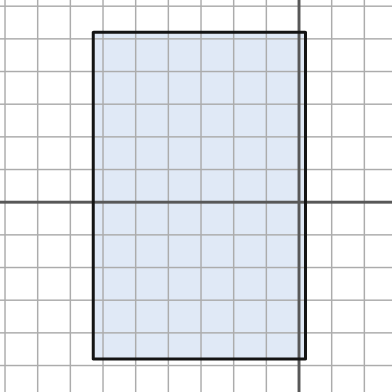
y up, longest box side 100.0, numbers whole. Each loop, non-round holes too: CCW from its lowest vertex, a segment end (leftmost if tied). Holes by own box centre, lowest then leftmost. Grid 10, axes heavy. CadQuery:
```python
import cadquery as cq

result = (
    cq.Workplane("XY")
    .moveTo(-63.0, -48.0)
    .lineTo(2.0, -48.0)
    .lineTo(2.0, 52.0)
    .lineTo(-63.0, 52.0)
    .close()
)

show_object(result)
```